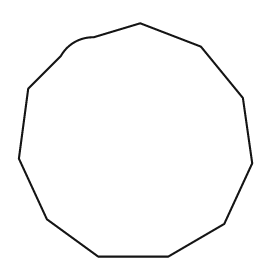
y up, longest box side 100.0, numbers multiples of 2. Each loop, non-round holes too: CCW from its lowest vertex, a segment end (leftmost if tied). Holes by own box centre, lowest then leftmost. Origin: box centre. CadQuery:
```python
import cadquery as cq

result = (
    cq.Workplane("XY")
    .moveTo(-16.0, -50.0)
    .lineTo(14.0, -50.0)
    .lineTo(38.0, -36.0)
    .lineTo(50.0, -10.0)
    .lineTo(46.0, 18.0)
    .lineTo(28.0, 40.0)
    .lineTo(2.0, 50.0)
    .lineTo(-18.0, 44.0)
    .threePointArc((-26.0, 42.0), (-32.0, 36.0))
    .lineTo(-46.0, 22.0)
    .lineTo(-50.0, -8.0)
    .lineTo(-38.0, -34.0)
    .close()
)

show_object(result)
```